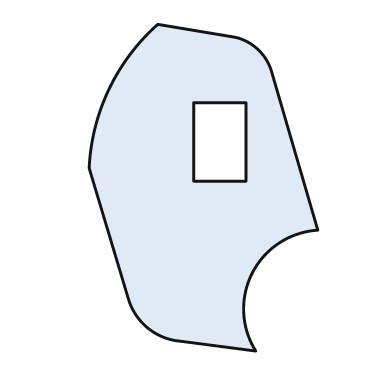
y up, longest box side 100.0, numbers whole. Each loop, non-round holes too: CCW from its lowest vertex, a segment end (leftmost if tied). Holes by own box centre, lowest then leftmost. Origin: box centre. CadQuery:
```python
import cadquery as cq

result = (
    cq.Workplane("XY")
    .moveTo(16.0, -50.0)
    .threePointArc((15.0, -26.0), (35.0, -13.0))
    .lineTo(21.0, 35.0)
    .threePointArc((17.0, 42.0), (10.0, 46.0))
    .lineTo(-14.0, 50.0)
    .threePointArc((-29.0, 30.0), (-35.0, 6.0))
    .lineTo(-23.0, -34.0)
    .threePointArc((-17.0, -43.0), (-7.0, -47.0))
    .close()
    .moveTo(-3.0, 2.0)
    .lineTo(13.0, 2.0)
    .lineTo(13.0, 26.0)
    .lineTo(-3.0, 26.0)
    .close()
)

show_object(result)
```